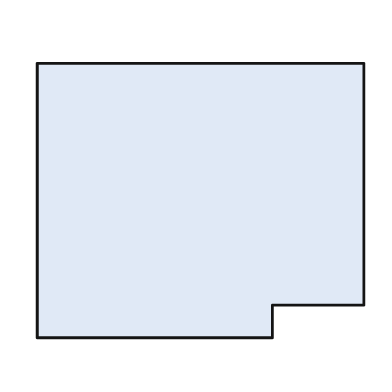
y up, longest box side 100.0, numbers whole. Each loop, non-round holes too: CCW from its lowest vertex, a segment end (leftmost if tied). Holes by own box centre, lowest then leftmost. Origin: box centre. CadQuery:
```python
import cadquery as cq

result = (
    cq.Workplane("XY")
    .moveTo(-50.0, -42.0)
    .lineTo(22.0, -42.0)
    .lineTo(22.0, -32.0)
    .lineTo(50.0, -32.0)
    .lineTo(50.0, 42.0)
    .lineTo(-50.0, 42.0)
    .close()
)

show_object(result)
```